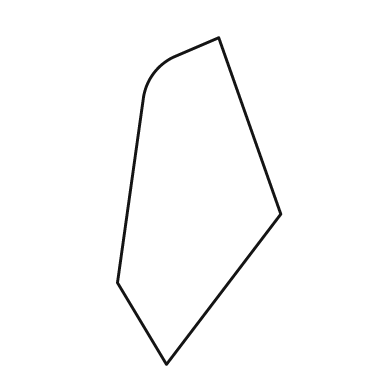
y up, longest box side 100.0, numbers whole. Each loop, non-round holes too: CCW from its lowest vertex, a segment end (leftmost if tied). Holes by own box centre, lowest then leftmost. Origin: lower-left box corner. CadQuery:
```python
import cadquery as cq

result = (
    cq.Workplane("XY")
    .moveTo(15.0, 0.0)
    .lineTo(50.0, 46.0)
    .lineTo(31.0, 100.0)
    .lineTo(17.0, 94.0)
    .threePointArc((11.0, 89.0), (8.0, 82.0))
    .lineTo(0.0, 25.0)
    .close()
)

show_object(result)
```